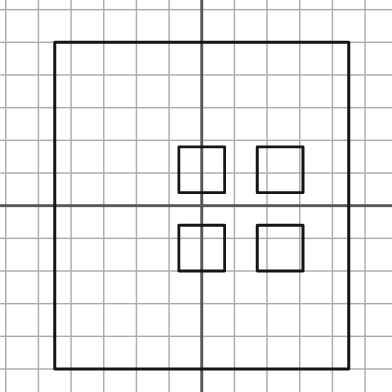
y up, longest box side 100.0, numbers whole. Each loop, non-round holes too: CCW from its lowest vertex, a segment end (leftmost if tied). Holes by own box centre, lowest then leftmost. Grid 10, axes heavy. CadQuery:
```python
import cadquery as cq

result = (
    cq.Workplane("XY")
    .moveTo(-45.0, -50.0)
    .lineTo(45.0, -50.0)
    .lineTo(45.0, 50.0)
    .lineTo(-45.0, 50.0)
    .close()
    .moveTo(-7.0, -20.0)
    .lineTo(7.0, -20.0)
    .lineTo(7.0, -6.0)
    .lineTo(-7.0, -6.0)
    .close()
    .moveTo(17.0, -20.0)
    .lineTo(31.0, -20.0)
    .lineTo(31.0, -6.0)
    .lineTo(17.0, -6.0)
    .close()
    .moveTo(-7.0, 4.0)
    .lineTo(7.0, 4.0)
    .lineTo(7.0, 18.0)
    .lineTo(-7.0, 18.0)
    .close()
    .moveTo(17.0, 4.0)
    .lineTo(31.0, 4.0)
    .lineTo(31.0, 18.0)
    .lineTo(17.0, 18.0)
    .close()
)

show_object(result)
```